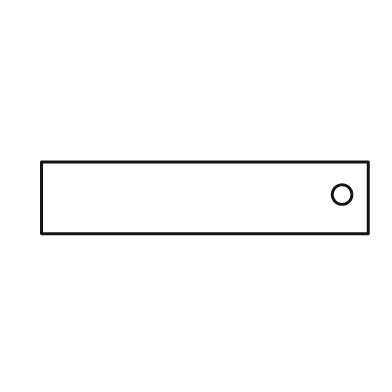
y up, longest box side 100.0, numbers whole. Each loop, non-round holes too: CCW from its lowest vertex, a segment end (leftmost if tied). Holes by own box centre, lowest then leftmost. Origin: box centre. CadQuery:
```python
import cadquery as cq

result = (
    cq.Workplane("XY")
    .moveTo(-50.0, -11.0)
    .lineTo(50.0, -11.0)
    .lineTo(50.0, 11.0)
    .lineTo(-50.0, 11.0)
    .close()
    .moveTo(42.0, 1.0)
    .circle(3.0)
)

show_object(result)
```